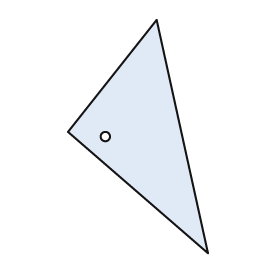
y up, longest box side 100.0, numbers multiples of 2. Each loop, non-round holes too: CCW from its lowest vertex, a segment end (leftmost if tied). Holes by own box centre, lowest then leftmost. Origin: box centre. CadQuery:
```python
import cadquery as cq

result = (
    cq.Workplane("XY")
    .moveTo(30.0, -50.0)
    .lineTo(8.0, 50.0)
    .lineTo(-30.0, 2.0)
    .close()
    .moveTo(-14.0, 0.0)
    .circle(2.0)
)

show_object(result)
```